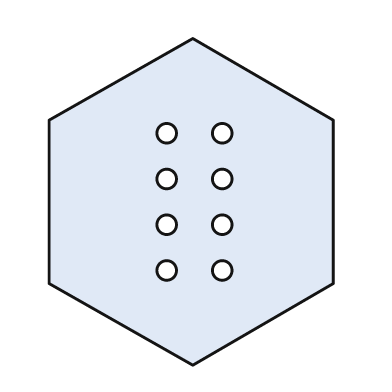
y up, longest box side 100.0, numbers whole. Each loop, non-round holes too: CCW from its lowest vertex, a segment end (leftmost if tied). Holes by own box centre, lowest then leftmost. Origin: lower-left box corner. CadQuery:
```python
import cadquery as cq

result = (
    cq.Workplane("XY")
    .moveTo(44.0, 0.0)
    .lineTo(87.0, 25.0)
    .lineTo(87.0, 75.0)
    .lineTo(44.0, 100.0)
    .lineTo(0.0, 75.0)
    .lineTo(0.0, 25.0)
    .close()
    .moveTo(36.0, 29.0)
    .circle(3.0)
    .moveTo(53.0, 29.0)
    .circle(3.0)
    .moveTo(36.0, 43.0)
    .circle(3.0)
    .moveTo(53.0, 43.0)
    .circle(3.0)
    .moveTo(36.0, 57.0)
    .circle(3.0)
    .moveTo(53.0, 57.0)
    .circle(3.0)
    .moveTo(36.0, 71.0)
    .circle(3.0)
    .moveTo(53.0, 71.0)
    .circle(3.0)
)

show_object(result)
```